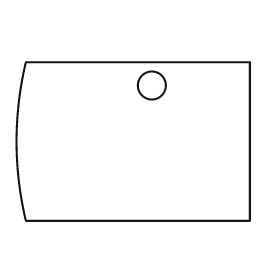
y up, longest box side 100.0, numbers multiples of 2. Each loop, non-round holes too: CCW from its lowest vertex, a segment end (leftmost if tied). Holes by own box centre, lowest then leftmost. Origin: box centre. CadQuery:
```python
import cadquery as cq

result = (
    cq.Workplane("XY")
    .moveTo(-46.0, -34.0)
    .lineTo(50.0, -34.0)
    .lineTo(50.0, 34.0)
    .lineTo(-46.0, 34.0)
    .threePointArc((-50.0, 0.0), (-46.0, -34.0))
    .close()
    .moveTo(8.0, 24.0)
    .circle(6.0)
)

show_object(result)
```